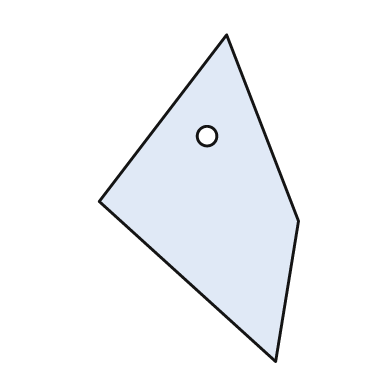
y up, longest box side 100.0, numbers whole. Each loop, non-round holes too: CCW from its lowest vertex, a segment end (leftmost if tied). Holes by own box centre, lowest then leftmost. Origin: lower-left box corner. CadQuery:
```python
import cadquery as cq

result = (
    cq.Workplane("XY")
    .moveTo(54.0, 0.0)
    .lineTo(61.0, 43.0)
    .lineTo(39.0, 100.0)
    .lineTo(0.0, 49.0)
    .close()
    .moveTo(33.0, 69.0)
    .circle(3.0)
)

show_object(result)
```